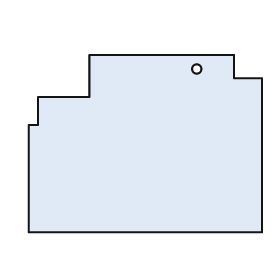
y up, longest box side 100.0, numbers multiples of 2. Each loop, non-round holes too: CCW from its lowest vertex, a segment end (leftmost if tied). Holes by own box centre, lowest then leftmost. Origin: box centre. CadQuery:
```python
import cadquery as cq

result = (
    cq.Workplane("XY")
    .moveTo(-50.0, -38.0)
    .lineTo(50.0, -38.0)
    .lineTo(50.0, 28.0)
    .lineTo(38.0, 28.0)
    .lineTo(38.0, 38.0)
    .lineTo(-24.0, 38.0)
    .lineTo(-24.0, 20.0)
    .lineTo(-46.0, 20.0)
    .lineTo(-46.0, 8.0)
    .lineTo(-50.0, 8.0)
    .close()
    .moveTo(22.0, 32.0)
    .circle(2.0)
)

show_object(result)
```